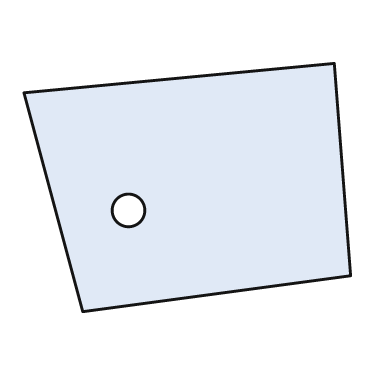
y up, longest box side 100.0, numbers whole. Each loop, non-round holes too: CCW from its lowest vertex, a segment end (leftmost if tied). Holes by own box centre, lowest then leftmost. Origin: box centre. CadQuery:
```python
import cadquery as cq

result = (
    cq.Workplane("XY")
    .moveTo(-32.0, -38.0)
    .lineTo(50.0, -27.0)
    .lineTo(45.0, 38.0)
    .lineTo(-50.0, 29.0)
    .close()
    .moveTo(-18.0, -7.0)
    .circle(5.0)
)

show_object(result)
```